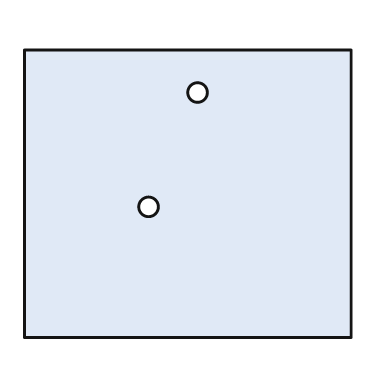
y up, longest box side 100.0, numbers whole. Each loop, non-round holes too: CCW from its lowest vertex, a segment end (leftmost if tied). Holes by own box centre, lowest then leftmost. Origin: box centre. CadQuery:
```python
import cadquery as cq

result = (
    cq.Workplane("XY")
    .moveTo(-50.0, -44.0)
    .lineTo(50.0, -44.0)
    .lineTo(50.0, 44.0)
    .lineTo(-50.0, 44.0)
    .close()
    .moveTo(-12.0, -4.0)
    .circle(3.0)
    .moveTo(3.0, 31.0)
    .circle(3.0)
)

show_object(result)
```